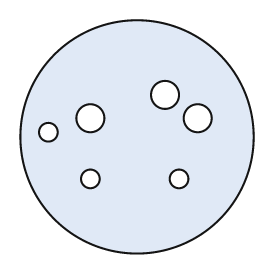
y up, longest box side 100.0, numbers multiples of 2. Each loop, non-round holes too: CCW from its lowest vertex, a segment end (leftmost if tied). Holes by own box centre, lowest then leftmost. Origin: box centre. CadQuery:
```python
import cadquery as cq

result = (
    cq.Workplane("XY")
    .moveTo(0.0, 0.0)
    .circle(50.0)
    .moveTo(-20.0, -18.0)
    .circle(4.0)
    .moveTo(18.0, -18.0)
    .circle(4.0)
    .moveTo(-38.0, 2.0)
    .circle(4.0)
    .moveTo(-20.0, 8.0)
    .circle(6.0)
    .moveTo(26.0, 8.0)
    .circle(6.0)
    .moveTo(12.0, 18.0)
    .circle(6.0)
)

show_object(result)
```